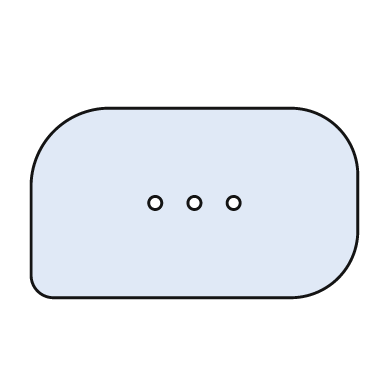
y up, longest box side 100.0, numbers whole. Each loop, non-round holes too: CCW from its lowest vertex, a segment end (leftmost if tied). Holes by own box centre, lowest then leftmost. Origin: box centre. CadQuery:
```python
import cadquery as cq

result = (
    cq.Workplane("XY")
    .moveTo(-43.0, -29.0)
    .lineTo(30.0, -29.0)
    .threePointArc((44.0, -23.0), (50.0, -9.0))
    .lineTo(50.0, 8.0)
    .threePointArc((44.0, 23.0), (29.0, 29.0))
    .lineTo(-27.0, 29.0)
    .threePointArc((-43.0, 22.0), (-50.0, 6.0))
    .lineTo(-50.0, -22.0)
    .threePointArc((-48.0, -27.0), (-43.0, -29.0))
    .close()
    .moveTo(-12.0, 0.0)
    .circle(2.0)
    .moveTo(0.0, 0.0)
    .circle(2.0)
    .moveTo(12.0, 0.0)
    .circle(2.0)
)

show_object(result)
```